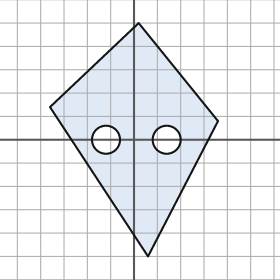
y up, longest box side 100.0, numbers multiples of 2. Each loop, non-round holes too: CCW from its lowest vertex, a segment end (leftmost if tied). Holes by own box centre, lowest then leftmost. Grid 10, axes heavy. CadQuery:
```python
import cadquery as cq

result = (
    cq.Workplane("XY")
    .moveTo(6.0, -50.0)
    .lineTo(36.0, 8.0)
    .lineTo(2.0, 50.0)
    .lineTo(-36.0, 14.0)
    .close()
    .moveTo(-12.0, 0.0)
    .circle(6.0)
    .moveTo(14.0, 0.0)
    .circle(6.0)
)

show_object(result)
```